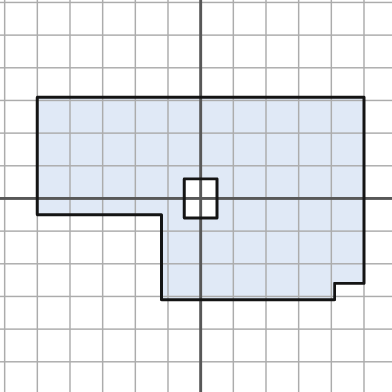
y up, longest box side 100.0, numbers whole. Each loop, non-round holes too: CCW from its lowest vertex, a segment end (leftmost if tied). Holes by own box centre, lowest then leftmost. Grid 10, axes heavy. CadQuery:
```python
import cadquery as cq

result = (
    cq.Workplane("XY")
    .moveTo(-12.0, -31.0)
    .lineTo(41.0, -31.0)
    .lineTo(41.0, -26.0)
    .lineTo(50.0, -26.0)
    .lineTo(50.0, 31.0)
    .lineTo(-50.0, 31.0)
    .lineTo(-50.0, -5.0)
    .lineTo(-12.0, -5.0)
    .close()
    .moveTo(-5.0, -6.0)
    .lineTo(5.0, -6.0)
    .lineTo(5.0, 6.0)
    .lineTo(-5.0, 6.0)
    .close()
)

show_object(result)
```